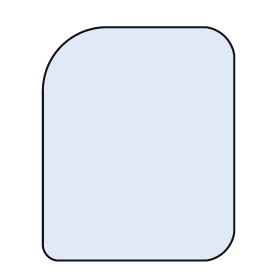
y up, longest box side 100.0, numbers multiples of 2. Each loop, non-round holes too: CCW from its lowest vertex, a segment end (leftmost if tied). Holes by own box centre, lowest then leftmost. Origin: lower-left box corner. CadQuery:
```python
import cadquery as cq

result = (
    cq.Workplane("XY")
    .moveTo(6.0, 0.0)
    .lineTo(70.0, 0.0)
    .threePointArc((78.0, 4.0), (82.0, 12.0))
    .lineTo(82.0, 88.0)
    .threePointArc((78.0, 96.0), (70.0, 100.0))
    .lineTo(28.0, 100.0)
    .threePointArc((8.0, 92.0), (0.0, 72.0))
    .lineTo(0.0, 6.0)
    .threePointArc((2.0, 2.0), (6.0, 0.0))
    .close()
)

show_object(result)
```